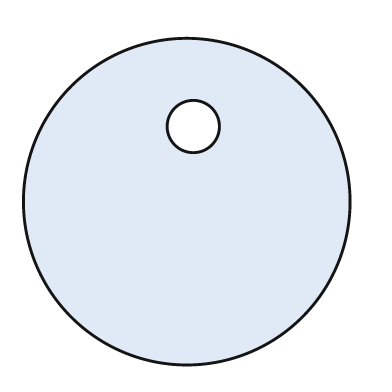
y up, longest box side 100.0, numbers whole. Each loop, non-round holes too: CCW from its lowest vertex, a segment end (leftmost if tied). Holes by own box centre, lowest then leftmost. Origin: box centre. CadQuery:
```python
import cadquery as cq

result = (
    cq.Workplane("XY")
    .moveTo(0.0, 0.0)
    .circle(50.0)
    .moveTo(2.0, 23.0)
    .circle(8.0)
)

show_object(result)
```